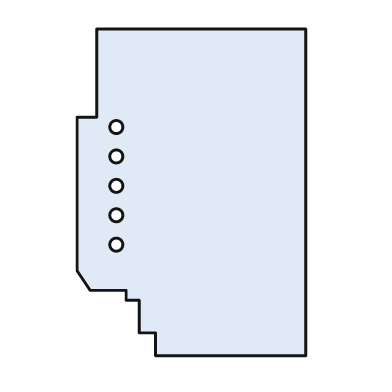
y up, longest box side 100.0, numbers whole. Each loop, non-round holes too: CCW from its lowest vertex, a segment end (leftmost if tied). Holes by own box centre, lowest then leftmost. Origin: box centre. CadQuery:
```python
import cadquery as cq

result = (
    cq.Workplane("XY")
    .moveTo(-11.0, -50.0)
    .lineTo(35.0, -50.0)
    .lineTo(35.0, 50.0)
    .lineTo(-29.0, 50.0)
    .lineTo(-29.0, 23.0)
    .lineTo(-35.0, 23.0)
    .lineTo(-35.0, -24.0)
    .lineTo(-31.0, -30.0)
    .lineTo(-20.0, -30.0)
    .lineTo(-20.0, -33.0)
    .lineTo(-16.0, -33.0)
    .lineTo(-16.0, -43.0)
    .lineTo(-11.0, -43.0)
    .close()
    .moveTo(-23.0, -16.0)
    .circle(2.0)
    .moveTo(-23.0, -7.0)
    .circle(2.0)
    .moveTo(-23.0, 2.0)
    .circle(2.0)
    .moveTo(-23.0, 11.0)
    .circle(2.0)
    .moveTo(-23.0, 20.0)
    .circle(2.0)
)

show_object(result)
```